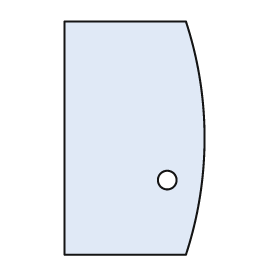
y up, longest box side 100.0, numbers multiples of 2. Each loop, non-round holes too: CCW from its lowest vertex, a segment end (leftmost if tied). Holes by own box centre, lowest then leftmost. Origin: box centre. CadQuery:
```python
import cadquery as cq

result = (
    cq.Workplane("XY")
    .moveTo(-30.0, -50.0)
    .lineTo(22.0, -50.0)
    .threePointArc((30.0, 0.0), (22.0, 50.0))
    .lineTo(-30.0, 50.0)
    .close()
    .moveTo(14.0, -18.0)
    .circle(4.0)
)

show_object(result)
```